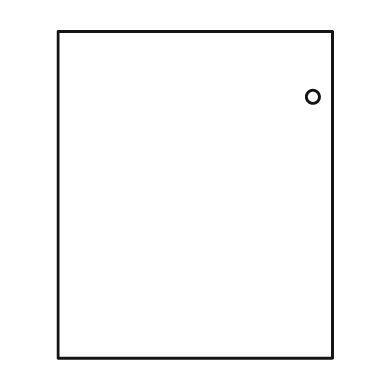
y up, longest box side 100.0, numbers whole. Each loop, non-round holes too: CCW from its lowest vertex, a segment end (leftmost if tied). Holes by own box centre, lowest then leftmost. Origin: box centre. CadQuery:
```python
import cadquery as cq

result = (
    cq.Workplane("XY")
    .moveTo(-42.0, -50.0)
    .lineTo(42.0, -50.0)
    .lineTo(42.0, 50.0)
    .lineTo(-42.0, 50.0)
    .close()
    .moveTo(36.0, 30.0)
    .circle(2.0)
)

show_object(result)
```